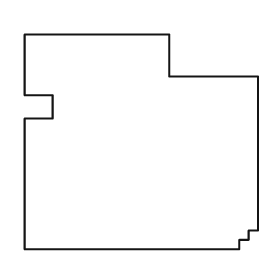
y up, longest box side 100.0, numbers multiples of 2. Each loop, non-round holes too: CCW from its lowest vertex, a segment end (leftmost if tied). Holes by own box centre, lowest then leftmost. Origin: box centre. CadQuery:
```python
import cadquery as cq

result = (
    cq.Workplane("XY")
    .moveTo(-50.0, -46.0)
    .lineTo(42.0, -46.0)
    .lineTo(42.0, -42.0)
    .lineTo(46.0, -42.0)
    .lineTo(46.0, -38.0)
    .lineTo(50.0, -38.0)
    .lineTo(50.0, 28.0)
    .lineTo(12.0, 28.0)
    .lineTo(12.0, 46.0)
    .lineTo(-50.0, 46.0)
    .lineTo(-50.0, 20.0)
    .lineTo(-38.0, 20.0)
    .lineTo(-38.0, 10.0)
    .lineTo(-50.0, 10.0)
    .close()
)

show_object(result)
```